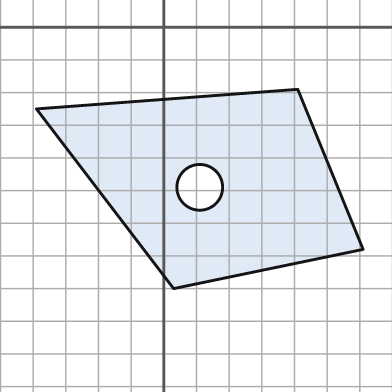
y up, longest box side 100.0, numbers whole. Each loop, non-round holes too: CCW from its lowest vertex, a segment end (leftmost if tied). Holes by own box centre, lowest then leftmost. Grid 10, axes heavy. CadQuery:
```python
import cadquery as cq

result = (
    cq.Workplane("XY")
    .moveTo(3.0, -80.0)
    .lineTo(61.0, -68.0)
    .lineTo(41.0, -19.0)
    .lineTo(-39.0, -25.0)
    .close()
    .moveTo(11.0, -49.0)
    .circle(7.0)
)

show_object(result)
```